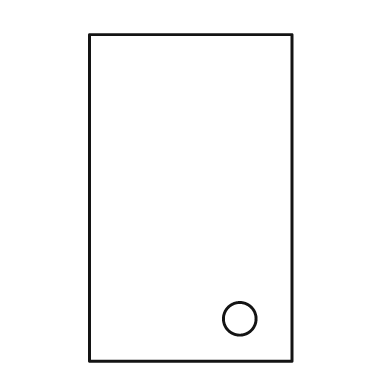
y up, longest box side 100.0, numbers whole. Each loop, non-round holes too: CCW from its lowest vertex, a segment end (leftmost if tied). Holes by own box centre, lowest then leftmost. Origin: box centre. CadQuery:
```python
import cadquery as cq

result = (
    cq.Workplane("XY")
    .moveTo(-31.0, -50.0)
    .lineTo(31.0, -50.0)
    .lineTo(31.0, 50.0)
    .lineTo(-31.0, 50.0)
    .close()
    .moveTo(15.0, -37.0)
    .circle(5.0)
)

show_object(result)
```